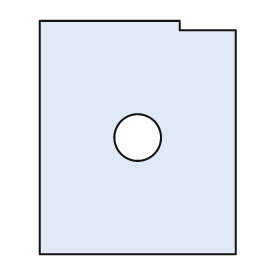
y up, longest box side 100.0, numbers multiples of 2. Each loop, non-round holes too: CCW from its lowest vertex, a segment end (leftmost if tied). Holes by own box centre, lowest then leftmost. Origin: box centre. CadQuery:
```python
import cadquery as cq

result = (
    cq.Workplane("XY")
    .moveTo(-42.0, -50.0)
    .lineTo(42.0, -50.0)
    .lineTo(42.0, 46.0)
    .lineTo(18.0, 46.0)
    .lineTo(18.0, 50.0)
    .lineTo(-42.0, 50.0)
    .close()
    .moveTo(0.0, 0.0)
    .circle(10.0)
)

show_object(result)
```